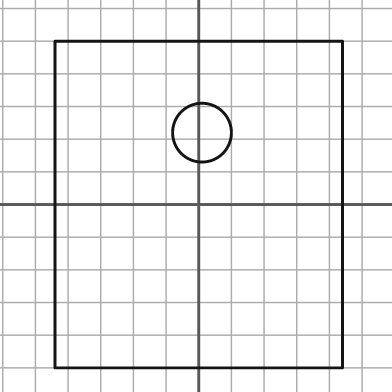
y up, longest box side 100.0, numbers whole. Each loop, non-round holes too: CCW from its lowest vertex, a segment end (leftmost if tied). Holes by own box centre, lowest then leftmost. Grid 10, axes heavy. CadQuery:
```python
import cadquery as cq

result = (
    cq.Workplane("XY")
    .moveTo(-44.0, -50.0)
    .lineTo(44.0, -50.0)
    .lineTo(44.0, 50.0)
    .lineTo(-44.0, 50.0)
    .close()
    .moveTo(1.0, 22.0)
    .circle(9.0)
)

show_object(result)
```